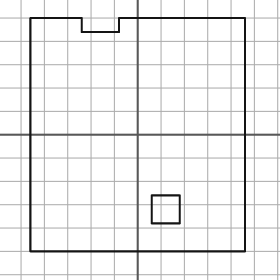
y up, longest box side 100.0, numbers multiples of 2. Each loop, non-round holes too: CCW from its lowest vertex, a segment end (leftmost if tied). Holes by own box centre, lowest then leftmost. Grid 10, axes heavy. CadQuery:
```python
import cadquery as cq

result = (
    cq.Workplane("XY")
    .moveTo(-46.0, -50.0)
    .lineTo(46.0, -50.0)
    .lineTo(46.0, 50.0)
    .lineTo(-8.0, 50.0)
    .lineTo(-8.0, 44.0)
    .lineTo(-24.0, 44.0)
    .lineTo(-24.0, 50.0)
    .lineTo(-46.0, 50.0)
    .close()
    .moveTo(6.0, -38.0)
    .lineTo(18.0, -38.0)
    .lineTo(18.0, -26.0)
    .lineTo(6.0, -26.0)
    .close()
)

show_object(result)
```